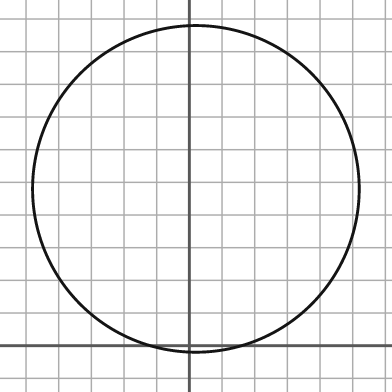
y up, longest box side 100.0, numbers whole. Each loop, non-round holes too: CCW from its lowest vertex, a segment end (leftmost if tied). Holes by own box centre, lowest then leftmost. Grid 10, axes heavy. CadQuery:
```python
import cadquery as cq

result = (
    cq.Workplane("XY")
    .moveTo(2.0, 48.0)
    .circle(50.0)
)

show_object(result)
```